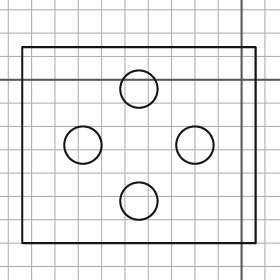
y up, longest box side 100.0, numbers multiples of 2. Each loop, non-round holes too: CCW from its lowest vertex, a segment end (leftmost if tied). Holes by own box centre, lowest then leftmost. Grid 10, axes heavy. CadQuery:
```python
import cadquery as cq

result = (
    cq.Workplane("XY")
    .moveTo(-94.0, -70.0)
    .lineTo(6.0, -70.0)
    .lineTo(6.0, 14.0)
    .lineTo(-94.0, 14.0)
    .close()
    .moveTo(-44.0, -52.0)
    .circle(8.0)
    .moveTo(-68.0, -28.0)
    .circle(8.0)
    .moveTo(-20.0, -28.0)
    .circle(8.0)
    .moveTo(-44.0, -4.0)
    .circle(8.0)
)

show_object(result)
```